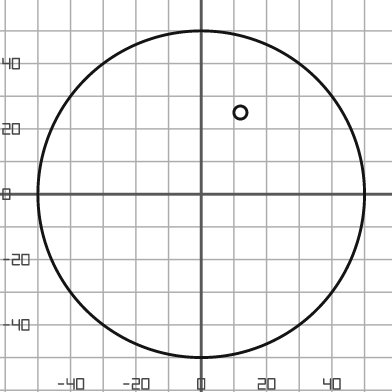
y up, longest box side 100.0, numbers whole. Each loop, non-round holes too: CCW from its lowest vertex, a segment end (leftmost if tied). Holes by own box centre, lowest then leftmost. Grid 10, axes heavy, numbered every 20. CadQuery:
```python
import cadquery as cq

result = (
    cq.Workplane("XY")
    .moveTo(0.0, 0.0)
    .circle(50.0)
    .moveTo(12.0, 25.0)
    .circle(2.0)
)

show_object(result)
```